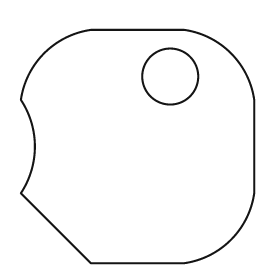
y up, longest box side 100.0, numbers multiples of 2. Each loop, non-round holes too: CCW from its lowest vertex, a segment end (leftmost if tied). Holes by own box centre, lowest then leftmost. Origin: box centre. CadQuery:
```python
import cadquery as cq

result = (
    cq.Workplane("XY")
    .moveTo(-20.0, -50.0)
    .lineTo(20.0, -50.0)
    .threePointArc((40.0, -40.0), (50.0, -20.0))
    .lineTo(50.0, 20.0)
    .threePointArc((40.0, 40.0), (20.0, 50.0))
    .lineTo(-20.0, 50.0)
    .threePointArc((-40.0, 40.0), (-50.0, 20.0))
    .threePointArc((-44.0, 0.0), (-50.0, -20.0))
    .close()
    .moveTo(14.0, 30.0)
    .circle(12.0)
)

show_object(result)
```